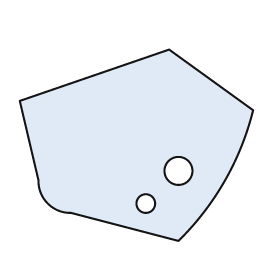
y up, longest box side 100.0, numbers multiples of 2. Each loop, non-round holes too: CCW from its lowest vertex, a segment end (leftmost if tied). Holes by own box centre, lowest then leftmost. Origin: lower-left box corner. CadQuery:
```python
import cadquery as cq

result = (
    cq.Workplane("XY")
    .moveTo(68.0, 0.0)
    .threePointArc((88.0, 26.0), (100.0, 56.0))
    .lineTo(64.0, 82.0)
    .lineTo(0.0, 60.0)
    .lineTo(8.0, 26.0)
    .threePointArc((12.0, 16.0), (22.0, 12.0))
    .close()
    .moveTo(54.0, 16.0)
    .circle(4.0)
    .moveTo(68.0, 30.0)
    .circle(6.0)
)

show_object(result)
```